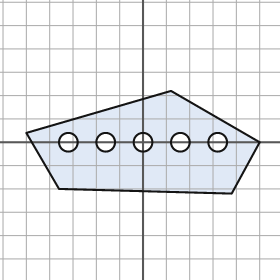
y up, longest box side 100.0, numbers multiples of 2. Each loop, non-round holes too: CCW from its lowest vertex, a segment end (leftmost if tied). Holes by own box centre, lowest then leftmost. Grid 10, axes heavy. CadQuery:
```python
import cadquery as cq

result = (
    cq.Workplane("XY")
    .moveTo(38.0, -22.0)
    .lineTo(50.0, 0.0)
    .lineTo(12.0, 22.0)
    .lineTo(-50.0, 4.0)
    .lineTo(-36.0, -20.0)
    .close()
    .moveTo(-32.0, 0.0)
    .circle(4.0)
    .moveTo(-16.0, 0.0)
    .circle(4.0)
    .moveTo(0.0, 0.0)
    .circle(4.0)
    .moveTo(16.0, 0.0)
    .circle(4.0)
    .moveTo(32.0, 0.0)
    .circle(4.0)
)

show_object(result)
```